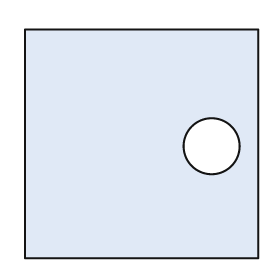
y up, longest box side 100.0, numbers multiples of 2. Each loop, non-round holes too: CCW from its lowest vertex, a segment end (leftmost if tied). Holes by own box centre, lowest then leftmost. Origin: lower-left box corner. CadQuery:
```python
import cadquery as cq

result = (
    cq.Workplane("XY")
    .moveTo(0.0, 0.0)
    .lineTo(100.0, 0.0)
    .lineTo(100.0, 98.0)
    .lineTo(0.0, 98.0)
    .close()
    .moveTo(80.0, 48.0)
    .circle(12.0)
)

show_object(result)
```